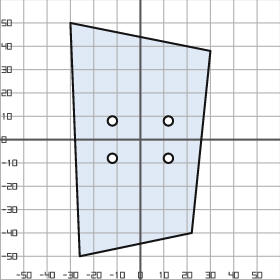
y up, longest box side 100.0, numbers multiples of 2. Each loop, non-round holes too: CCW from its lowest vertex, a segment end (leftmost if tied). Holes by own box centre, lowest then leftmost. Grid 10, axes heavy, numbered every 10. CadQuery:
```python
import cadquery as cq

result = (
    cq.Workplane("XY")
    .moveTo(-26.0, -50.0)
    .lineTo(22.0, -40.0)
    .lineTo(30.0, 38.0)
    .lineTo(-30.0, 50.0)
    .close()
    .moveTo(-12.0, -8.0)
    .circle(2.0)
    .moveTo(12.0, -8.0)
    .circle(2.0)
    .moveTo(-12.0, 8.0)
    .circle(2.0)
    .moveTo(12.0, 8.0)
    .circle(2.0)
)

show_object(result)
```